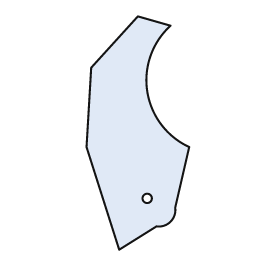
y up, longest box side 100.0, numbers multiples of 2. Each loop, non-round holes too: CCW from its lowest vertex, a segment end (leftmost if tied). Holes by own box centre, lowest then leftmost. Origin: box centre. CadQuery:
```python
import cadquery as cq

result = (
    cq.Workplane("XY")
    .moveTo(-8.0, -50.0)
    .lineTo(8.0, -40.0)
    .threePointArc((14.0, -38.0), (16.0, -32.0))
    .lineTo(22.0, -6.0)
    .threePointArc((4.0, 18.0), (14.0, 46.0))
    .lineTo(0.0, 50.0)
    .lineTo(-20.0, 28.0)
    .lineTo(-22.0, -6.0)
    .close()
    .moveTo(4.0, -28.0)
    .circle(2.0)
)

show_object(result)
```